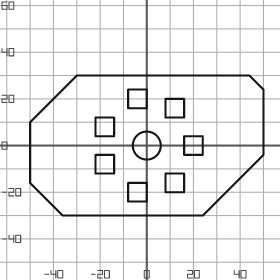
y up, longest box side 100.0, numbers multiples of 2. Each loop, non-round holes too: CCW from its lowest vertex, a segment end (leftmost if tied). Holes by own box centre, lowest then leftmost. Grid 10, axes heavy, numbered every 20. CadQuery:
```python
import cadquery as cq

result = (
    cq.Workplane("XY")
    .moveTo(-36.0, -30.0)
    .lineTo(24.0, -30.0)
    .lineTo(50.0, -4.0)
    .lineTo(50.0, 24.0)
    .lineTo(44.0, 30.0)
    .lineTo(-30.0, 30.0)
    .lineTo(-50.0, 10.0)
    .lineTo(-50.0, -16.0)
    .close()
    .moveTo(-8.0, -24.0)
    .lineTo(0.0, -24.0)
    .lineTo(0.0, -16.0)
    .lineTo(-8.0, -16.0)
    .close()
    .moveTo(8.0, -20.0)
    .lineTo(16.0, -20.0)
    .lineTo(16.0, -12.0)
    .lineTo(8.0, -12.0)
    .close()
    .moveTo(-22.0, -12.0)
    .lineTo(-14.0, -12.0)
    .lineTo(-14.0, -4.0)
    .lineTo(-22.0, -4.0)
    .close()
    .moveTo(0.0, 0.0)
    .circle(6.0)
    .moveTo(16.0, -4.0)
    .lineTo(24.0, -4.0)
    .lineTo(24.0, 4.0)
    .lineTo(16.0, 4.0)
    .close()
    .moveTo(-22.0, 4.0)
    .lineTo(-14.0, 4.0)
    .lineTo(-14.0, 12.0)
    .lineTo(-22.0, 12.0)
    .close()
    .moveTo(8.0, 12.0)
    .lineTo(16.0, 12.0)
    .lineTo(16.0, 20.0)
    .lineTo(8.0, 20.0)
    .close()
    .moveTo(-8.0, 16.0)
    .lineTo(0.0, 16.0)
    .lineTo(0.0, 24.0)
    .lineTo(-8.0, 24.0)
    .close()
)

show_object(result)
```